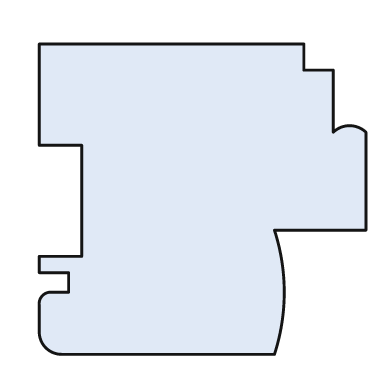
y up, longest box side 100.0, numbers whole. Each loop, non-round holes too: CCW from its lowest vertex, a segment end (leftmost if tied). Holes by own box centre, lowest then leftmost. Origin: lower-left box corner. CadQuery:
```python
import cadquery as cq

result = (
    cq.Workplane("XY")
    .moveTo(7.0, 0.0)
    .lineTo(72.0, 0.0)
    .threePointArc((75.0, 19.0), (72.0, 38.0))
    .lineTo(100.0, 38.0)
    .lineTo(100.0, 68.0)
    .threePointArc((95.0, 70.0), (90.0, 68.0))
    .lineTo(90.0, 87.0)
    .lineTo(81.0, 87.0)
    .lineTo(81.0, 95.0)
    .lineTo(0.0, 95.0)
    .lineTo(0.0, 64.0)
    .lineTo(13.0, 64.0)
    .lineTo(13.0, 30.0)
    .lineTo(0.0, 30.0)
    .lineTo(0.0, 25.0)
    .lineTo(9.0, 25.0)
    .lineTo(9.0, 19.0)
    .lineTo(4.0, 19.0)
    .threePointArc((1.0, 18.0), (0.0, 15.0))
    .lineTo(0.0, 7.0)
    .threePointArc((2.0, 2.0), (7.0, 0.0))
    .close()
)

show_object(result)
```